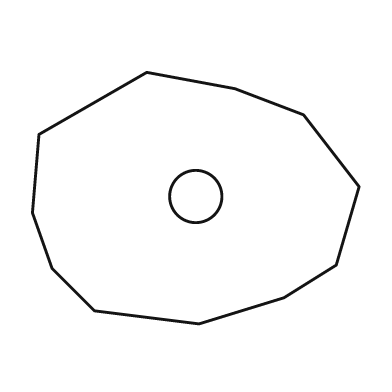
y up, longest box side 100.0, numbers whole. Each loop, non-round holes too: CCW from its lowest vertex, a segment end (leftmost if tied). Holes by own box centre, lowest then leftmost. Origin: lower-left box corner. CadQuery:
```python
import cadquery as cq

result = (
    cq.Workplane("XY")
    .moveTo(51.0, 0.0)
    .lineTo(77.0, 8.0)
    .lineTo(93.0, 18.0)
    .lineTo(100.0, 42.0)
    .lineTo(83.0, 64.0)
    .lineTo(62.0, 72.0)
    .lineTo(35.0, 77.0)
    .lineTo(2.0, 58.0)
    .lineTo(0.0, 34.0)
    .lineTo(6.0, 17.0)
    .lineTo(19.0, 4.0)
    .close()
    .moveTo(50.0, 39.0)
    .circle(8.0)
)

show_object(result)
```